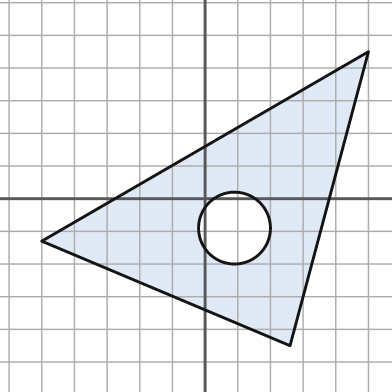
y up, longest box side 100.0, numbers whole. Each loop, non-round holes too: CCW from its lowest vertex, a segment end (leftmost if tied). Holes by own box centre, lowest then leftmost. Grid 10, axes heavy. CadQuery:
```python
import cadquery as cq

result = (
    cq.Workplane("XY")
    .moveTo(26.0, -45.0)
    .lineTo(50.0, 45.0)
    .lineTo(-50.0, -13.0)
    .close()
    .moveTo(9.0, -9.0)
    .circle(11.0)
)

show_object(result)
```